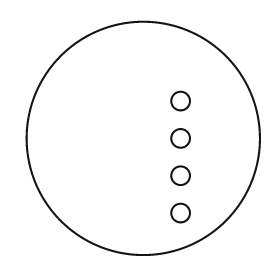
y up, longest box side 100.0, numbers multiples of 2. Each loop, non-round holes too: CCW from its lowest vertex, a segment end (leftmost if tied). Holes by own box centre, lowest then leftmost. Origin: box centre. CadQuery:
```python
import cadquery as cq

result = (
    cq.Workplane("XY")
    .moveTo(0.0, 0.0)
    .circle(50.0)
    .moveTo(16.0, -32.0)
    .circle(4.0)
    .moveTo(16.0, -16.0)
    .circle(4.0)
    .moveTo(16.0, 0.0)
    .circle(4.0)
    .moveTo(16.0, 16.0)
    .circle(4.0)
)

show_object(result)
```